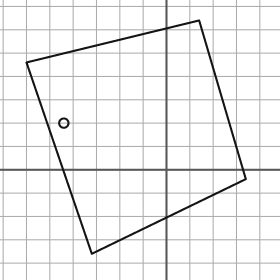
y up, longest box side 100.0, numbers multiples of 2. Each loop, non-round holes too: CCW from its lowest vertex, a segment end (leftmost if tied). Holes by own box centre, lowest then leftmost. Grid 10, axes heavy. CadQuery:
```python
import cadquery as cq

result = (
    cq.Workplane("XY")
    .moveTo(-32.0, -36.0)
    .lineTo(34.0, -4.0)
    .lineTo(14.0, 64.0)
    .lineTo(-60.0, 46.0)
    .close()
    .moveTo(-44.0, 20.0)
    .circle(2.0)
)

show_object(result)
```